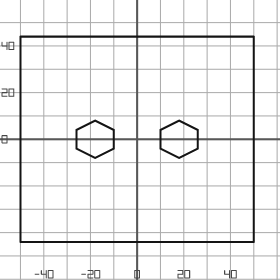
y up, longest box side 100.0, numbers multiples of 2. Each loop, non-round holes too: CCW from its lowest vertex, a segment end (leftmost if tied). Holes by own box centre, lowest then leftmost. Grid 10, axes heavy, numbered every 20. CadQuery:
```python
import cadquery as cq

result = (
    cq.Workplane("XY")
    .moveTo(-50.0, -44.0)
    .lineTo(50.0, -44.0)
    .lineTo(50.0, 44.0)
    .lineTo(-50.0, 44.0)
    .close()
    .moveTo(-18.0, -8.0)
    .lineTo(-10.0, -4.0)
    .lineTo(-10.0, 4.0)
    .lineTo(-18.0, 8.0)
    .lineTo(-26.0, 4.0)
    .lineTo(-26.0, -4.0)
    .close()
    .moveTo(18.0, -8.0)
    .lineTo(26.0, -4.0)
    .lineTo(26.0, 4.0)
    .lineTo(18.0, 8.0)
    .lineTo(10.0, 4.0)
    .lineTo(10.0, -4.0)
    .close()
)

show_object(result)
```